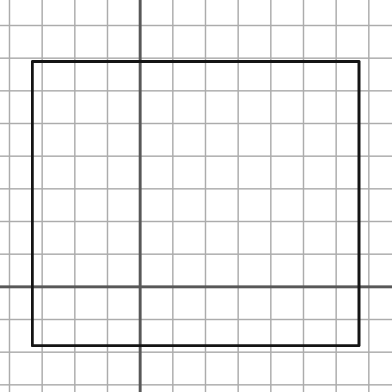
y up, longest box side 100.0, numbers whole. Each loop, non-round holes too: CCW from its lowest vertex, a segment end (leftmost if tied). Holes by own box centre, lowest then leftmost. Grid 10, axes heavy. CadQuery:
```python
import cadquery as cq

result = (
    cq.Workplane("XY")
    .moveTo(-33.0, -18.0)
    .lineTo(67.0, -18.0)
    .lineTo(67.0, 69.0)
    .lineTo(-33.0, 69.0)
    .close()
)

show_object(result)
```